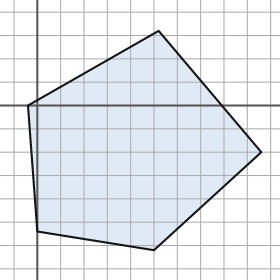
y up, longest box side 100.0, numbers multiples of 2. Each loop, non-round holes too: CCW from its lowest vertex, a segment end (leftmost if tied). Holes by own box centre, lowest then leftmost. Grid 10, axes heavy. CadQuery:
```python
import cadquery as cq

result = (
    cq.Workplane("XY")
    .moveTo(50.0, -62.0)
    .lineTo(96.0, -20.0)
    .lineTo(52.0, 32.0)
    .lineTo(-4.0, 0.0)
    .lineTo(0.0, -54.0)
    .close()
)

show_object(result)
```